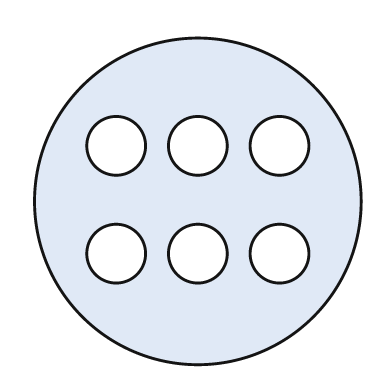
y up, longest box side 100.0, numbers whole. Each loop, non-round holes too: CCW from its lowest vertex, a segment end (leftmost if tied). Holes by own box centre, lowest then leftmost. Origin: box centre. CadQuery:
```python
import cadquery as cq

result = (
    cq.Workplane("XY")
    .moveTo(0.0, 0.0)
    .circle(50.0)
    .moveTo(-25.0, -16.0)
    .circle(9.0)
    .moveTo(0.0, -16.0)
    .circle(9.0)
    .moveTo(25.0, -16.0)
    .circle(9.0)
    .moveTo(-25.0, 17.0)
    .circle(9.0)
    .moveTo(0.0, 17.0)
    .circle(9.0)
    .moveTo(25.0, 17.0)
    .circle(9.0)
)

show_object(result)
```